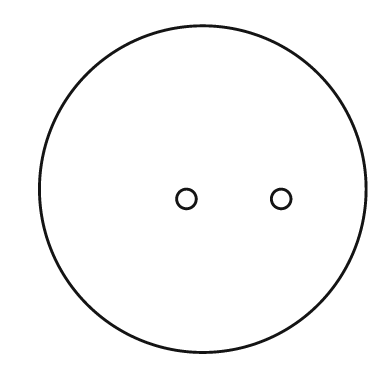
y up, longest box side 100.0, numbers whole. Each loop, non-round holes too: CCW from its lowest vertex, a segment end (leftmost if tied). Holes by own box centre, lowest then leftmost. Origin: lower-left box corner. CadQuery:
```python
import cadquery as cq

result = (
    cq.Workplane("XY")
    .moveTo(50.0, 50.0)
    .circle(50.0)
    .moveTo(45.0, 47.0)
    .circle(3.0)
    .moveTo(74.0, 47.0)
    .circle(3.0)
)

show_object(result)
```